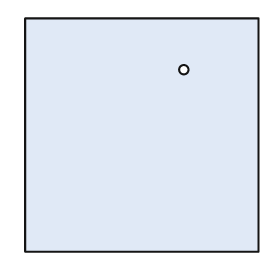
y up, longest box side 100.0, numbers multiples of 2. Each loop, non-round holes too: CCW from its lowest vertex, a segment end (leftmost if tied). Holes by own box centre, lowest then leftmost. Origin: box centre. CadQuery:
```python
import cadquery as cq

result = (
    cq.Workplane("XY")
    .moveTo(-50.0, -50.0)
    .lineTo(50.0, -50.0)
    .lineTo(50.0, 50.0)
    .lineTo(-50.0, 50.0)
    .close()
    .moveTo(18.0, 28.0)
    .circle(2.0)
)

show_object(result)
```